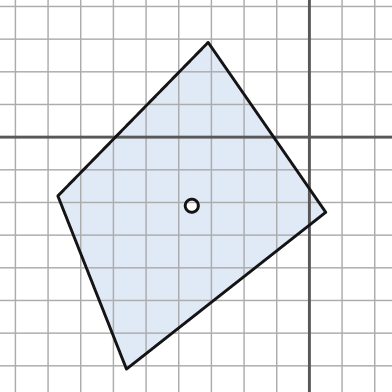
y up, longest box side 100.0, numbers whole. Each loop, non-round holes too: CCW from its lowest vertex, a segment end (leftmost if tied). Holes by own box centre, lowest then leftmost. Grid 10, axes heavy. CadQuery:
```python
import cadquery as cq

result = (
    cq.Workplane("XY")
    .moveTo(-56.0, -71.0)
    .lineTo(5.0, -23.0)
    .lineTo(-31.0, 29.0)
    .lineTo(-77.0, -18.0)
    .close()
    .moveTo(-36.0, -21.0)
    .circle(2.0)
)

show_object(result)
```